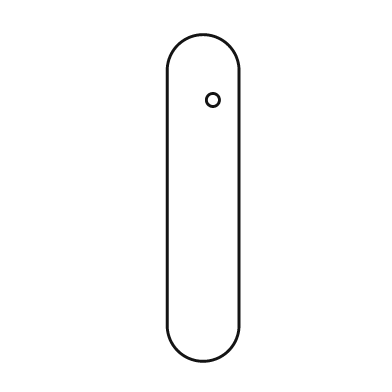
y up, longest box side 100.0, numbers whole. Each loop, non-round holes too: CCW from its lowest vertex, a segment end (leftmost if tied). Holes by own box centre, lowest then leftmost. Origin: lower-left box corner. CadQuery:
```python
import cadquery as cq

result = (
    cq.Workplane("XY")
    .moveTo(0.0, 11.0)
    .threePointArc((11.0, 0.0), (22.0, 11.0))
    .lineTo(22.0, 89.0)
    .threePointArc((11.0, 100.0), (0.0, 89.0))
    .close()
    .moveTo(14.0, 80.0)
    .circle(2.0)
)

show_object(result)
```